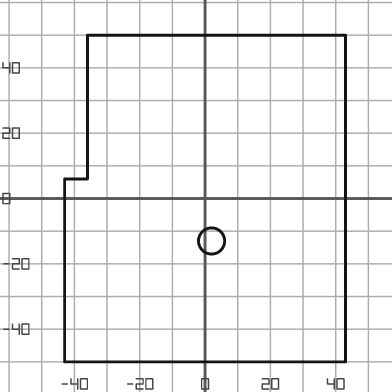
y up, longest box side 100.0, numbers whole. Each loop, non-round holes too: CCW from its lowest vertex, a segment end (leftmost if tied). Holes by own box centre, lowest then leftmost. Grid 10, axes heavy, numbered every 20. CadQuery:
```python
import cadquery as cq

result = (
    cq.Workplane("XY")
    .moveTo(-43.0, -50.0)
    .lineTo(43.0, -50.0)
    .lineTo(43.0, 50.0)
    .lineTo(-36.0, 50.0)
    .lineTo(-36.0, 6.0)
    .lineTo(-43.0, 6.0)
    .close()
    .moveTo(2.0, -13.0)
    .circle(4.0)
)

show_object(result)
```